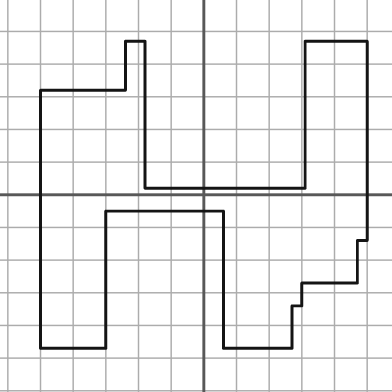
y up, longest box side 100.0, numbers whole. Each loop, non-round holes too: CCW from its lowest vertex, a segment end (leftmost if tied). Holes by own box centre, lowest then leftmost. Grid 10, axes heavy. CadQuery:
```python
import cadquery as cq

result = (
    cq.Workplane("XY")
    .moveTo(-50.0, -47.0)
    .lineTo(-30.0, -47.0)
    .lineTo(-30.0, -5.0)
    .lineTo(6.0, -5.0)
    .lineTo(6.0, -47.0)
    .lineTo(27.0, -47.0)
    .lineTo(27.0, -34.0)
    .lineTo(30.0, -34.0)
    .lineTo(30.0, -27.0)
    .lineTo(47.0, -27.0)
    .lineTo(47.0, -14.0)
    .lineTo(50.0, -14.0)
    .lineTo(50.0, 47.0)
    .lineTo(31.0, 47.0)
    .lineTo(31.0, 2.0)
    .lineTo(-18.0, 2.0)
    .lineTo(-18.0, 47.0)
    .lineTo(-24.0, 47.0)
    .lineTo(-24.0, 32.0)
    .lineTo(-50.0, 32.0)
    .close()
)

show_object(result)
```